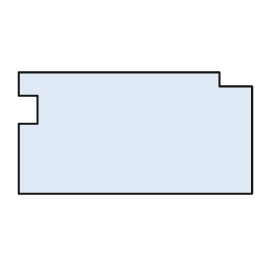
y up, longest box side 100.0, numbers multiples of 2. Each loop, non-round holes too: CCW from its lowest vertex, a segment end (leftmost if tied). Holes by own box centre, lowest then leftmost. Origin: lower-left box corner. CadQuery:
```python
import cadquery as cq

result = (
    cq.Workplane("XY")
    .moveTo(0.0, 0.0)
    .lineTo(100.0, 0.0)
    .lineTo(100.0, 46.0)
    .lineTo(86.0, 46.0)
    .lineTo(86.0, 52.0)
    .lineTo(0.0, 52.0)
    .lineTo(0.0, 42.0)
    .lineTo(8.0, 42.0)
    .lineTo(8.0, 30.0)
    .lineTo(0.0, 30.0)
    .close()
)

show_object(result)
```